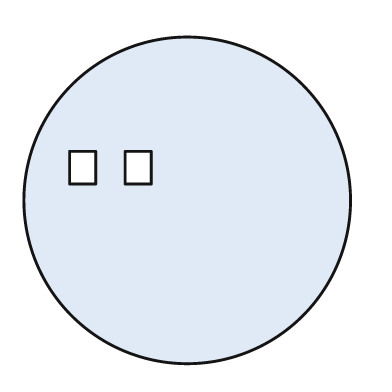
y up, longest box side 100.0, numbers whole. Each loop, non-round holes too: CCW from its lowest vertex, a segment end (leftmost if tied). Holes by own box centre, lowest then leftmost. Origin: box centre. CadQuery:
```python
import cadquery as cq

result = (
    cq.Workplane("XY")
    .moveTo(0.0, 0.0)
    .circle(50.0)
    .moveTo(-36.0, 5.0)
    .lineTo(-28.0, 5.0)
    .lineTo(-28.0, 15.0)
    .lineTo(-36.0, 15.0)
    .close()
    .moveTo(-19.0, 5.0)
    .lineTo(-11.0, 5.0)
    .lineTo(-11.0, 15.0)
    .lineTo(-19.0, 15.0)
    .close()
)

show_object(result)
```